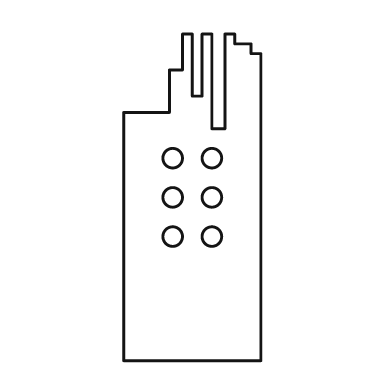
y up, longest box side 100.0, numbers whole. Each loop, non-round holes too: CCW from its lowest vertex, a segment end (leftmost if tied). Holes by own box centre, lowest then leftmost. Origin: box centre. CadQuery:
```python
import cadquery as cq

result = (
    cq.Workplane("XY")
    .moveTo(-21.0, -50.0)
    .lineTo(21.0, -50.0)
    .lineTo(21.0, 44.0)
    .lineTo(18.0, 44.0)
    .lineTo(18.0, 47.0)
    .lineTo(13.0, 47.0)
    .lineTo(13.0, 50.0)
    .lineTo(10.0, 50.0)
    .lineTo(10.0, 21.0)
    .lineTo(6.0, 21.0)
    .lineTo(6.0, 50.0)
    .lineTo(3.0, 50.0)
    .lineTo(3.0, 31.0)
    .lineTo(0.0, 31.0)
    .lineTo(0.0, 50.0)
    .lineTo(-3.0, 50.0)
    .lineTo(-3.0, 39.0)
    .lineTo(-7.0, 39.0)
    .lineTo(-7.0, 26.0)
    .lineTo(-21.0, 26.0)
    .close()
    .moveTo(-6.0, -12.0)
    .circle(3.0)
    .moveTo(6.0, -12.0)
    .circle(3.0)
    .moveTo(-6.0, 0.0)
    .circle(3.0)
    .moveTo(6.0, 0.0)
    .circle(3.0)
    .moveTo(-6.0, 12.0)
    .circle(3.0)
    .moveTo(6.0, 12.0)
    .circle(3.0)
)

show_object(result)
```